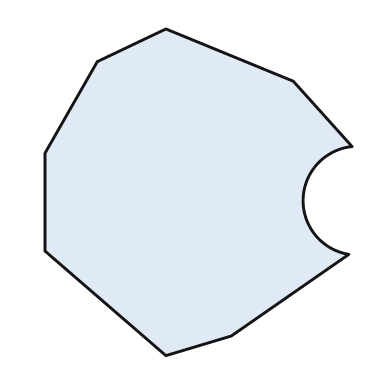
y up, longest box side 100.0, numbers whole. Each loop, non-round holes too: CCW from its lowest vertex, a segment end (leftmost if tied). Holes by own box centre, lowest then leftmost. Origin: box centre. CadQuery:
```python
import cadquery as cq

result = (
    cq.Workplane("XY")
    .moveTo(-10.0, -50.0)
    .lineTo(10.0, -44.0)
    .lineTo(46.0, -19.0)
    .threePointArc((32.0, -2.0), (47.0, 14.0))
    .lineTo(29.0, 34.0)
    .lineTo(-10.0, 50.0)
    .lineTo(-31.0, 40.0)
    .lineTo(-47.0, 12.0)
    .lineTo(-47.0, -18.0)
    .close()
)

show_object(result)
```